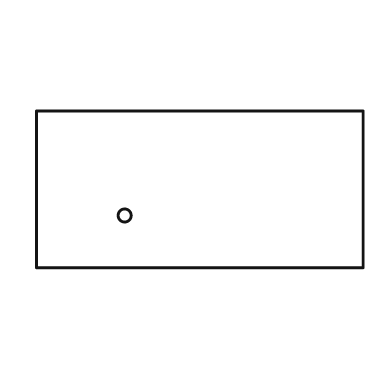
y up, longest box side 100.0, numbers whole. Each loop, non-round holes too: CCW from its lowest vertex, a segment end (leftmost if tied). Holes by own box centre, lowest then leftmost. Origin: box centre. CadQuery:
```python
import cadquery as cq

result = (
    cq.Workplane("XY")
    .moveTo(-50.0, -24.0)
    .lineTo(50.0, -24.0)
    .lineTo(50.0, 24.0)
    .lineTo(-50.0, 24.0)
    .close()
    .moveTo(-23.0, -8.0)
    .circle(2.0)
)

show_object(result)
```